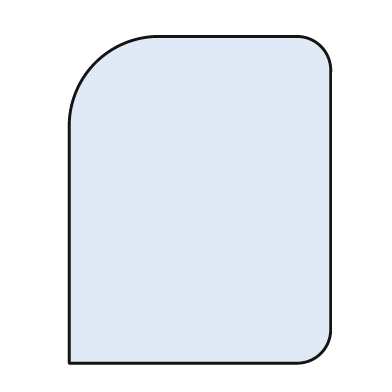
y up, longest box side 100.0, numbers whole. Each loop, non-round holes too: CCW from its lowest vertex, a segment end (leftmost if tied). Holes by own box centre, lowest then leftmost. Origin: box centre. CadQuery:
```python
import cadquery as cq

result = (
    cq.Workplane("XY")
    .moveTo(-40.0, -50.0)
    .lineTo(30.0, -50.0)
    .threePointArc((37.0, -47.0), (40.0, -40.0))
    .lineTo(40.0, 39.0)
    .threePointArc((37.0, 47.0), (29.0, 50.0))
    .lineTo(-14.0, 50.0)
    .threePointArc((-32.0, 42.0), (-40.0, 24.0))
    .close()
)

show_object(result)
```